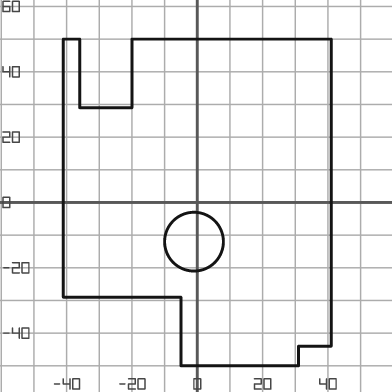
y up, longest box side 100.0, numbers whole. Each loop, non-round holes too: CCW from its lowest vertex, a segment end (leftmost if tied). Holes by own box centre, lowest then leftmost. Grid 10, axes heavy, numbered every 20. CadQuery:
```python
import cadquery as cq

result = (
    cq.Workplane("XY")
    .moveTo(-5.0, -50.0)
    .lineTo(31.0, -50.0)
    .lineTo(31.0, -44.0)
    .lineTo(41.0, -44.0)
    .lineTo(41.0, 50.0)
    .lineTo(-20.0, 50.0)
    .lineTo(-20.0, 29.0)
    .lineTo(-36.0, 29.0)
    .lineTo(-36.0, 50.0)
    .lineTo(-41.0, 50.0)
    .lineTo(-41.0, -29.0)
    .lineTo(-5.0, -29.0)
    .close()
    .moveTo(-1.0, -12.0)
    .circle(9.0)
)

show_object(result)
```